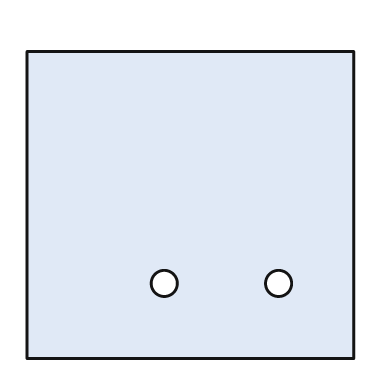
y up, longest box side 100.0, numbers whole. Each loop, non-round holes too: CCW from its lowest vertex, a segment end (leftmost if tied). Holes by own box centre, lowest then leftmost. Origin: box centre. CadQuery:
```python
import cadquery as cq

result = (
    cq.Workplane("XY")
    .moveTo(-50.0, -47.0)
    .lineTo(50.0, -47.0)
    .lineTo(50.0, 47.0)
    .lineTo(-50.0, 47.0)
    .close()
    .moveTo(-8.0, -24.0)
    .circle(4.0)
    .moveTo(27.0, -24.0)
    .circle(4.0)
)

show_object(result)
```